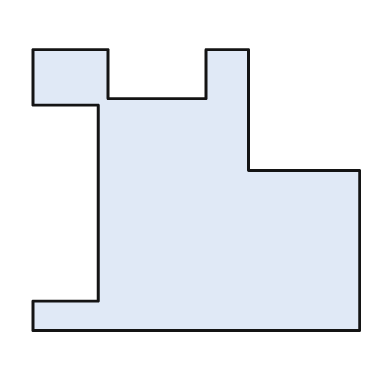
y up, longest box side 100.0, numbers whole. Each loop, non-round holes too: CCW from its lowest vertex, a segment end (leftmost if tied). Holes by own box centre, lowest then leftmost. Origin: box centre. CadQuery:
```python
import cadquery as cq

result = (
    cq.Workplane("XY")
    .moveTo(-50.0, -43.0)
    .lineTo(50.0, -43.0)
    .lineTo(50.0, 6.0)
    .lineTo(16.0, 6.0)
    .lineTo(16.0, 43.0)
    .lineTo(3.0, 43.0)
    .lineTo(3.0, 28.0)
    .lineTo(-27.0, 28.0)
    .lineTo(-27.0, 43.0)
    .lineTo(-50.0, 43.0)
    .lineTo(-50.0, 26.0)
    .lineTo(-30.0, 26.0)
    .lineTo(-30.0, -34.0)
    .lineTo(-50.0, -34.0)
    .close()
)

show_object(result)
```